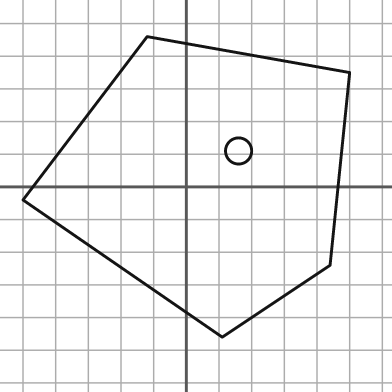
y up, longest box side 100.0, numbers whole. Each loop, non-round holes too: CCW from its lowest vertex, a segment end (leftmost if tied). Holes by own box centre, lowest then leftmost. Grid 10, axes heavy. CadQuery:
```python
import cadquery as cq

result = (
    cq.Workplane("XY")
    .moveTo(11.0, -46.0)
    .lineTo(44.0, -24.0)
    .lineTo(50.0, 35.0)
    .lineTo(-12.0, 46.0)
    .lineTo(-50.0, -4.0)
    .close()
    .moveTo(16.0, 11.0)
    .circle(4.0)
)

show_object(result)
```